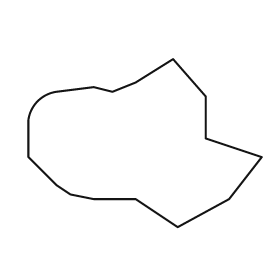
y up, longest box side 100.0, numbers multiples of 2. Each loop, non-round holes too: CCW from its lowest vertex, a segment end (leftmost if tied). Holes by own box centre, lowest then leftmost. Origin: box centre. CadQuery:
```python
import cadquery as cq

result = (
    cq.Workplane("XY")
    .moveTo(14.0, -36.0)
    .lineTo(36.0, -24.0)
    .lineTo(50.0, -6.0)
    .lineTo(26.0, 2.0)
    .lineTo(26.0, 20.0)
    .lineTo(12.0, 36.0)
    .lineTo(-4.0, 26.0)
    .lineTo(-14.0, 22.0)
    .lineTo(-22.0, 24.0)
    .lineTo(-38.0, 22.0)
    .threePointArc((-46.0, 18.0), (-50.0, 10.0))
    .lineTo(-50.0, -6.0)
    .lineTo(-38.0, -18.0)
    .lineTo(-32.0, -22.0)
    .lineTo(-22.0, -24.0)
    .lineTo(-4.0, -24.0)
    .close()
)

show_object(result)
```